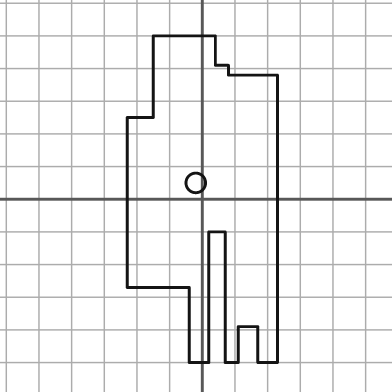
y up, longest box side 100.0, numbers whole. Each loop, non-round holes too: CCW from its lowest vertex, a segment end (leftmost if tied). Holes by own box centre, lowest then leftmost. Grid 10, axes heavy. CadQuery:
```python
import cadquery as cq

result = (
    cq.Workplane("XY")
    .moveTo(-4.0, -50.0)
    .lineTo(2.0, -50.0)
    .lineTo(2.0, -10.0)
    .lineTo(7.0, -10.0)
    .lineTo(7.0, -50.0)
    .lineTo(11.0, -50.0)
    .lineTo(11.0, -39.0)
    .lineTo(17.0, -39.0)
    .lineTo(17.0, -50.0)
    .lineTo(23.0, -50.0)
    .lineTo(23.0, 38.0)
    .lineTo(8.0, 38.0)
    .lineTo(8.0, 41.0)
    .lineTo(4.0, 41.0)
    .lineTo(4.0, 50.0)
    .lineTo(-15.0, 50.0)
    .lineTo(-15.0, 25.0)
    .lineTo(-23.0, 25.0)
    .lineTo(-23.0, -27.0)
    .lineTo(-4.0, -27.0)
    .close()
    .moveTo(-2.0, 5.0)
    .circle(3.0)
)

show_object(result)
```